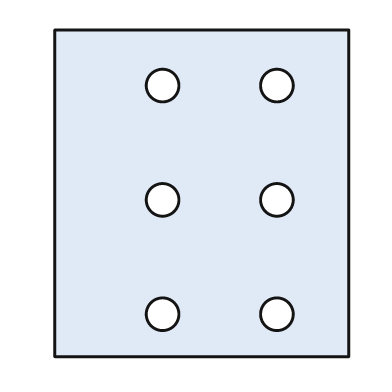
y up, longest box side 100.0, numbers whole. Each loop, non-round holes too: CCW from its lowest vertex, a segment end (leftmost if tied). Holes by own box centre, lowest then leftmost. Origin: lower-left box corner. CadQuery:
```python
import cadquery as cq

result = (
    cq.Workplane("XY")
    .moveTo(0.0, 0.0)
    .lineTo(90.0, 0.0)
    .lineTo(90.0, 100.0)
    .lineTo(0.0, 100.0)
    .close()
    .moveTo(33.0, 13.0)
    .circle(5.0)
    .moveTo(68.0, 13.0)
    .circle(5.0)
    .moveTo(33.0, 48.0)
    .circle(5.0)
    .moveTo(68.0, 48.0)
    .circle(5.0)
    .moveTo(33.0, 83.0)
    .circle(5.0)
    .moveTo(68.0, 83.0)
    .circle(5.0)
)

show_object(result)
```